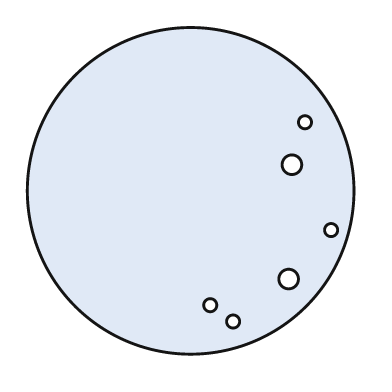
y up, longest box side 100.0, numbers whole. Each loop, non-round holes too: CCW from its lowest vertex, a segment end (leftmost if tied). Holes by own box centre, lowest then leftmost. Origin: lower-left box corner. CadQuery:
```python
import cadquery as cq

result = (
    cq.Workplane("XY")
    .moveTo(50.0, 50.0)
    .circle(50.0)
    .moveTo(63.0, 10.0)
    .circle(2.0)
    .moveTo(56.0, 15.0)
    .circle(2.0)
    .moveTo(80.0, 23.0)
    .circle(3.0)
    .moveTo(93.0, 38.0)
    .circle(2.0)
    .moveTo(81.0, 58.0)
    .circle(3.0)
    .moveTo(85.0, 71.0)
    .circle(2.0)
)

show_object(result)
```